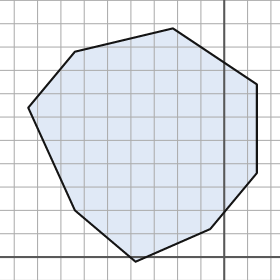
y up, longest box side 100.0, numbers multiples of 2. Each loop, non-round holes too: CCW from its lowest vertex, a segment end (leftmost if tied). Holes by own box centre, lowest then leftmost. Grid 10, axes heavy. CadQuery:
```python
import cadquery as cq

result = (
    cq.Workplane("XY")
    .moveTo(-38.0, -2.0)
    .lineTo(-6.0, 12.0)
    .lineTo(14.0, 36.0)
    .lineTo(14.0, 74.0)
    .lineTo(-22.0, 98.0)
    .lineTo(-64.0, 88.0)
    .lineTo(-84.0, 64.0)
    .lineTo(-64.0, 20.0)
    .close()
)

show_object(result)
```